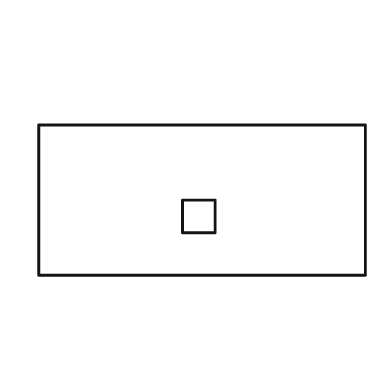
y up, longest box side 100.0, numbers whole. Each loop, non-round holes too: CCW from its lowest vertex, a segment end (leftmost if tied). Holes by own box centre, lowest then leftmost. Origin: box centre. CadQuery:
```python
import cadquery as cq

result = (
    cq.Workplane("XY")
    .moveTo(-50.0, -23.0)
    .lineTo(50.0, -23.0)
    .lineTo(50.0, 23.0)
    .lineTo(-50.0, 23.0)
    .close()
    .moveTo(-6.0, -10.0)
    .lineTo(4.0, -10.0)
    .lineTo(4.0, 0.0)
    .lineTo(-6.0, 0.0)
    .close()
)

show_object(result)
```